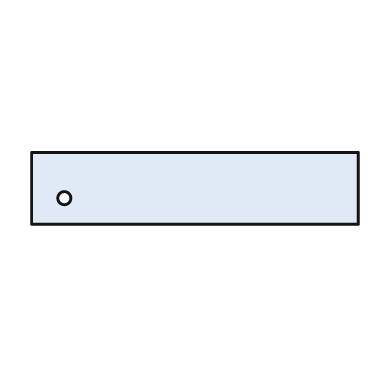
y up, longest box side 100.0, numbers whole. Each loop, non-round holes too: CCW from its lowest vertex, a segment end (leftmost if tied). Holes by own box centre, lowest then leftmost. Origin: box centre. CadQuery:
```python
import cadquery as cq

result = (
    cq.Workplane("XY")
    .moveTo(-50.0, -11.0)
    .lineTo(50.0, -11.0)
    .lineTo(50.0, 11.0)
    .lineTo(-50.0, 11.0)
    .close()
    .moveTo(-40.0, -3.0)
    .circle(2.0)
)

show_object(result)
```